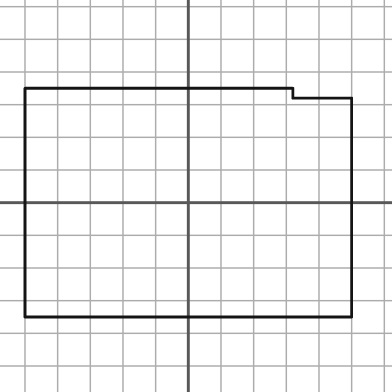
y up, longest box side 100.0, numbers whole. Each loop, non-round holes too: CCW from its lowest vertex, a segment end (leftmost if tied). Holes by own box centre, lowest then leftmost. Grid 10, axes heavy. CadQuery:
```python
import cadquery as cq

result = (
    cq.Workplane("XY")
    .moveTo(-50.0, -35.0)
    .lineTo(50.0, -35.0)
    .lineTo(50.0, 32.0)
    .lineTo(32.0, 32.0)
    .lineTo(32.0, 35.0)
    .lineTo(-50.0, 35.0)
    .close()
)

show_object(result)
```